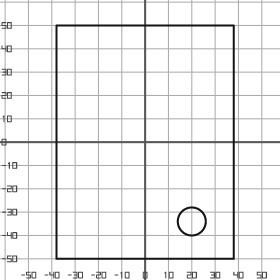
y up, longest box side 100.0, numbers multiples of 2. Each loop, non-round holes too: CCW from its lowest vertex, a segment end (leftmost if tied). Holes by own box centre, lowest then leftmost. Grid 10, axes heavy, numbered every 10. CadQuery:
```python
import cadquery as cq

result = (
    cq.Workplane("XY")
    .moveTo(-38.0, -50.0)
    .lineTo(38.0, -50.0)
    .lineTo(38.0, 50.0)
    .lineTo(-38.0, 50.0)
    .close()
    .moveTo(20.0, -34.0)
    .circle(6.0)
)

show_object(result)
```